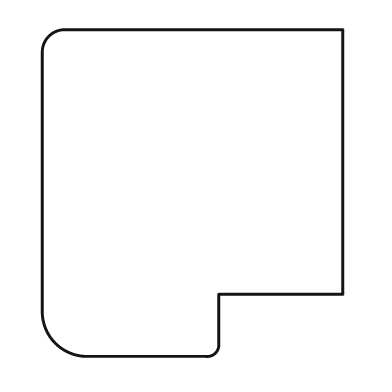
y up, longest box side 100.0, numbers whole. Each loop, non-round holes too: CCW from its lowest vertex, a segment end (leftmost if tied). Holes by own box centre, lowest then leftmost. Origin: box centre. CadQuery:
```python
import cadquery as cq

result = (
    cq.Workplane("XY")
    .moveTo(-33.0, -50.0)
    .lineTo(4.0, -50.0)
    .threePointArc((7.0, -49.0), (8.0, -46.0))
    .lineTo(8.0, -31.0)
    .lineTo(46.0, -31.0)
    .lineTo(46.0, 50.0)
    .lineTo(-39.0, 50.0)
    .threePointArc((-44.0, 48.0), (-46.0, 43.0))
    .lineTo(-46.0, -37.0)
    .threePointArc((-42.0, -46.0), (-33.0, -50.0))
    .close()
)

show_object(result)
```